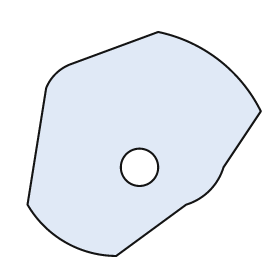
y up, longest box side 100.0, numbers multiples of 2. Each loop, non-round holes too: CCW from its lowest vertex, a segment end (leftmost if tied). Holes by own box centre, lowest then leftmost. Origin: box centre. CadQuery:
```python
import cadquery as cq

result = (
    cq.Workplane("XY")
    .moveTo(-12.0, -48.0)
    .lineTo(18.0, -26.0)
    .threePointArc((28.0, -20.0), (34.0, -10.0))
    .lineTo(50.0, 14.0)
    .threePointArc((32.0, 36.0), (6.0, 48.0))
    .lineTo(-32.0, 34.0)
    .threePointArc((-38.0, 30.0), (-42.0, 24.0))
    .lineTo(-50.0, -26.0)
    .threePointArc((-34.0, -42.0), (-12.0, -48.0))
    .close()
    .moveTo(-2.0, -10.0)
    .circle(8.0)
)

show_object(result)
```